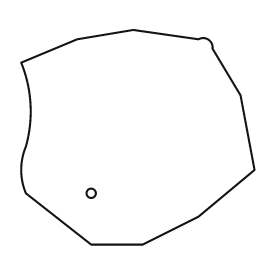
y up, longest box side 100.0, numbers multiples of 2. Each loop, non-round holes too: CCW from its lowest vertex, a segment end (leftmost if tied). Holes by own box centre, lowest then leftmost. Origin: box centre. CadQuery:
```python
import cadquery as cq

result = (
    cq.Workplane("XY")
    .moveTo(-20.0, -46.0)
    .lineTo(2.0, -46.0)
    .lineTo(26.0, -34.0)
    .lineTo(50.0, -14.0)
    .lineTo(44.0, 18.0)
    .lineTo(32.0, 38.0)
    .threePointArc((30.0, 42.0), (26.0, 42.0))
    .lineTo(-2.0, 46.0)
    .lineTo(-26.0, 42.0)
    .lineTo(-50.0, 32.0)
    .threePointArc((-46.0, 14.0), (-48.0, -4.0))
    .threePointArc((-50.0, -14.0), (-48.0, -24.0))
    .close()
    .moveTo(-20.0, -24.0)
    .circle(2.0)
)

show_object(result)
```